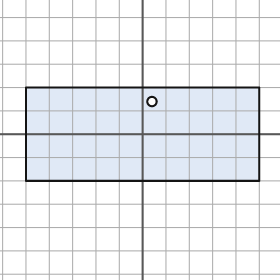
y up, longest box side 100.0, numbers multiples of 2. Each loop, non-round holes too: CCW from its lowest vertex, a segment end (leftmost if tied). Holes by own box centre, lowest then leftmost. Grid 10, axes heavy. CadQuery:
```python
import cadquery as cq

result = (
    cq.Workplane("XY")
    .moveTo(-50.0, -20.0)
    .lineTo(50.0, -20.0)
    .lineTo(50.0, 20.0)
    .lineTo(-50.0, 20.0)
    .close()
    .moveTo(4.0, 14.0)
    .circle(2.0)
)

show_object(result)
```